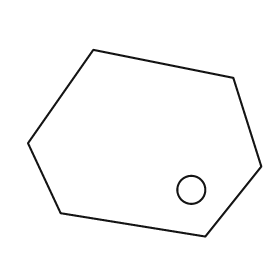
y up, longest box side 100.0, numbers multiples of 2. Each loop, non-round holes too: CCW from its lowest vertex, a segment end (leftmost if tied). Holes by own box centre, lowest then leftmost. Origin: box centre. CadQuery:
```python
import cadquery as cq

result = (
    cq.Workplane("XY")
    .moveTo(26.0, -40.0)
    .lineTo(50.0, -10.0)
    .lineTo(38.0, 28.0)
    .lineTo(-22.0, 40.0)
    .lineTo(-50.0, 0.0)
    .lineTo(-36.0, -30.0)
    .close()
    .moveTo(20.0, -20.0)
    .circle(6.0)
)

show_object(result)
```